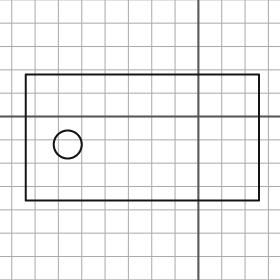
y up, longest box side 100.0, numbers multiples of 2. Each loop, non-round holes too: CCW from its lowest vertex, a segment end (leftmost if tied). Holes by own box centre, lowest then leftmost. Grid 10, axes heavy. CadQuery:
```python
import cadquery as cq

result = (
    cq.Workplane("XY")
    .moveTo(-74.0, -36.0)
    .lineTo(26.0, -36.0)
    .lineTo(26.0, 18.0)
    .lineTo(-74.0, 18.0)
    .close()
    .moveTo(-56.0, -12.0)
    .circle(6.0)
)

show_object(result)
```